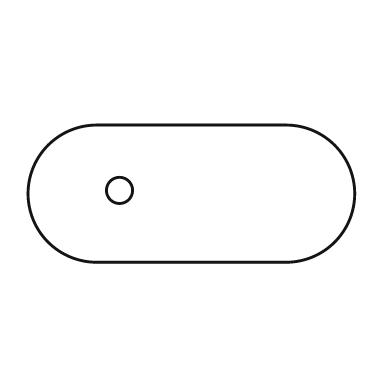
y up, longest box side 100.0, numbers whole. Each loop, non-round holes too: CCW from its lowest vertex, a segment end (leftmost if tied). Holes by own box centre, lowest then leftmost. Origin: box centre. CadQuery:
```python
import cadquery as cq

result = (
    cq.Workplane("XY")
    .moveTo(-29.0, -21.0)
    .lineTo(29.0, -21.0)
    .threePointArc((50.0, 0.0), (29.0, 21.0))
    .lineTo(-29.0, 21.0)
    .threePointArc((-50.0, 0.0), (-29.0, -21.0))
    .close()
    .moveTo(-22.0, 1.0)
    .circle(4.0)
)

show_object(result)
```